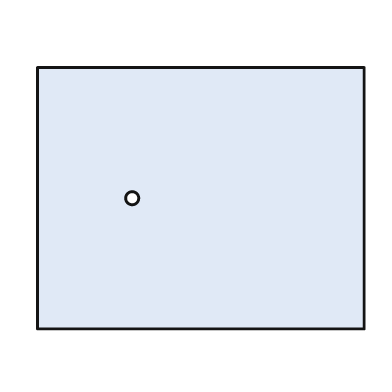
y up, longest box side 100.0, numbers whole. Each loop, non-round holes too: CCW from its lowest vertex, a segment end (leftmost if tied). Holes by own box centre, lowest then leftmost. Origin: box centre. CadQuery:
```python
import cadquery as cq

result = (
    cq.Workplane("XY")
    .moveTo(-50.0, -40.0)
    .lineTo(50.0, -40.0)
    .lineTo(50.0, 40.0)
    .lineTo(-50.0, 40.0)
    .close()
    .moveTo(-21.0, 0.0)
    .circle(2.0)
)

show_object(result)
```